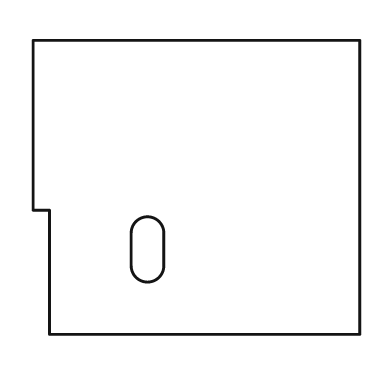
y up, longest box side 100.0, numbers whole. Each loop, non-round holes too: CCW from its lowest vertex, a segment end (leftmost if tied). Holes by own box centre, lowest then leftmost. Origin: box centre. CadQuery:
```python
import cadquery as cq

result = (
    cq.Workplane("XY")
    .moveTo(-45.0, -45.0)
    .lineTo(50.0, -45.0)
    .lineTo(50.0, 45.0)
    .lineTo(-50.0, 45.0)
    .lineTo(-50.0, -7.0)
    .lineTo(-45.0, -7.0)
    .close()
    .moveTo(-20.0, -24.0)
    .threePointArc((-15.0, -29.0), (-10.0, -24.0))
    .lineTo(-10.0, -14.0)
    .threePointArc((-15.0, -9.0), (-20.0, -14.0))
    .close()
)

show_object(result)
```